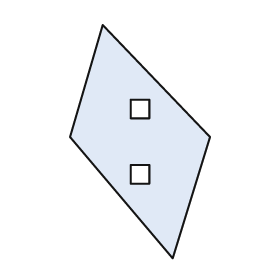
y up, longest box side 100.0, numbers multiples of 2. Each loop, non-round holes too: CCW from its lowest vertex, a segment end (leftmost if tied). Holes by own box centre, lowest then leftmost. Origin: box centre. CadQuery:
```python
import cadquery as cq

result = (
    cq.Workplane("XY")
    .moveTo(14.0, -50.0)
    .lineTo(30.0, 2.0)
    .lineTo(-16.0, 50.0)
    .lineTo(-30.0, 2.0)
    .close()
    .moveTo(-4.0, -18.0)
    .lineTo(4.0, -18.0)
    .lineTo(4.0, -10.0)
    .lineTo(-4.0, -10.0)
    .close()
    .moveTo(-4.0, 10.0)
    .lineTo(4.0, 10.0)
    .lineTo(4.0, 18.0)
    .lineTo(-4.0, 18.0)
    .close()
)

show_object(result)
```